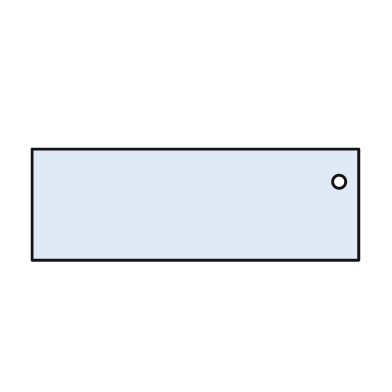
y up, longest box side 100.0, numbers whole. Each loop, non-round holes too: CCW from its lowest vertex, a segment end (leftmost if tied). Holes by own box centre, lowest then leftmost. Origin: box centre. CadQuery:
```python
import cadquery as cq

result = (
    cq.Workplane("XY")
    .moveTo(-50.0, -17.0)
    .lineTo(50.0, -17.0)
    .lineTo(50.0, 17.0)
    .lineTo(-50.0, 17.0)
    .close()
    .moveTo(44.0, 7.0)
    .circle(2.0)
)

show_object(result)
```